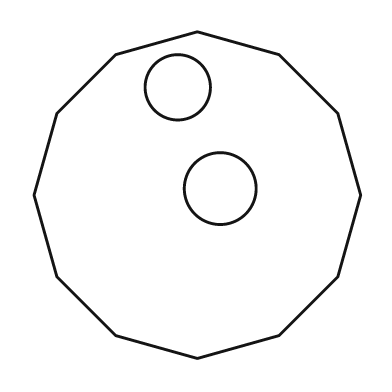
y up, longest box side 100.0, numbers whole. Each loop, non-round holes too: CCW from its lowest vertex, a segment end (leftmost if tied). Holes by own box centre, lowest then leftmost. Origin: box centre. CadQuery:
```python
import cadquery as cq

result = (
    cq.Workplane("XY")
    .moveTo(0.0, -50.0)
    .lineTo(25.0, -43.0)
    .lineTo(43.0, -25.0)
    .lineTo(50.0, 0.0)
    .lineTo(43.0, 25.0)
    .lineTo(25.0, 43.0)
    .lineTo(0.0, 50.0)
    .lineTo(-25.0, 43.0)
    .lineTo(-43.0, 25.0)
    .lineTo(-50.0, 0.0)
    .lineTo(-43.0, -25.0)
    .lineTo(-25.0, -43.0)
    .close()
    .moveTo(7.0, 2.0)
    .circle(11.0)
    .moveTo(-6.0, 33.0)
    .circle(10.0)
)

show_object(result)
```